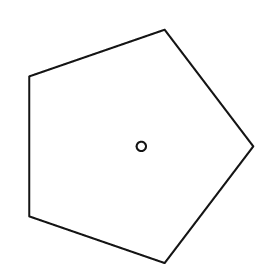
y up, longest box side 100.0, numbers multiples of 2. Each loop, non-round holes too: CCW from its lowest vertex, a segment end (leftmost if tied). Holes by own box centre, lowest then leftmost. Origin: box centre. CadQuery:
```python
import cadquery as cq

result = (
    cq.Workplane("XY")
    .moveTo(10.0, -50.0)
    .lineTo(48.0, 0.0)
    .lineTo(10.0, 50.0)
    .lineTo(-48.0, 30.0)
    .lineTo(-48.0, -30.0)
    .close()
    .moveTo(0.0, 0.0)
    .circle(2.0)
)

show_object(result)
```